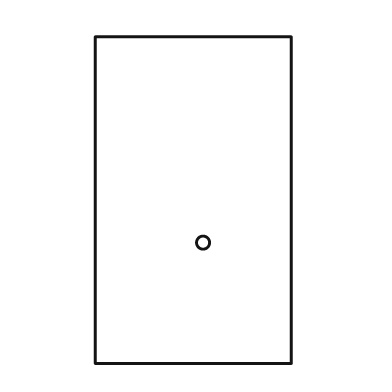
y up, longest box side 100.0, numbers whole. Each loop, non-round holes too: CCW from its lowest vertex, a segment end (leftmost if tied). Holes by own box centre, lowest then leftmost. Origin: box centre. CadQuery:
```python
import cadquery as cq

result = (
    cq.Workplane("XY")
    .moveTo(-30.0, -50.0)
    .lineTo(30.0, -50.0)
    .lineTo(30.0, 50.0)
    .lineTo(-30.0, 50.0)
    .close()
    .moveTo(3.0, -13.0)
    .circle(2.0)
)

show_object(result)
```